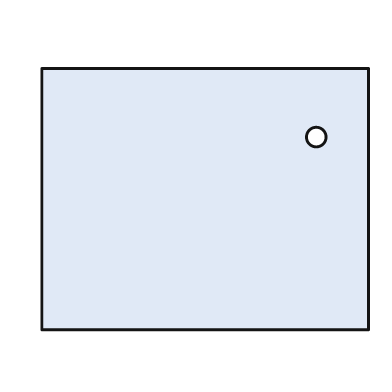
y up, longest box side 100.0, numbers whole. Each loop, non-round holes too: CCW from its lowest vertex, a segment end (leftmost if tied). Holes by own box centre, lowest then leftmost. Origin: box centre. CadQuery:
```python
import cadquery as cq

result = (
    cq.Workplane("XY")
    .moveTo(-50.0, -40.0)
    .lineTo(50.0, -40.0)
    .lineTo(50.0, 40.0)
    .lineTo(-50.0, 40.0)
    .close()
    .moveTo(34.0, 19.0)
    .circle(3.0)
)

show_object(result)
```